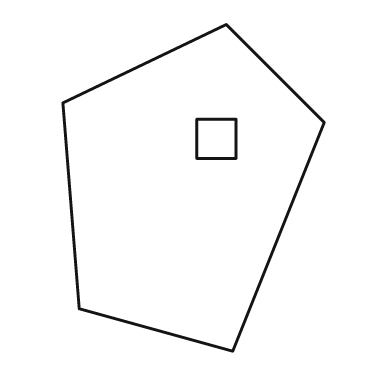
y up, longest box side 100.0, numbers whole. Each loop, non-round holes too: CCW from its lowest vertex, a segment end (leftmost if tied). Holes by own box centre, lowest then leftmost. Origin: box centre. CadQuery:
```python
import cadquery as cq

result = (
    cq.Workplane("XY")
    .moveTo(12.0, -50.0)
    .lineTo(40.0, 20.0)
    .lineTo(10.0, 50.0)
    .lineTo(-40.0, 26.0)
    .lineTo(-35.0, -37.0)
    .close()
    .moveTo(1.0, 9.0)
    .lineTo(13.0, 9.0)
    .lineTo(13.0, 21.0)
    .lineTo(1.0, 21.0)
    .close()
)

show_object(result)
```